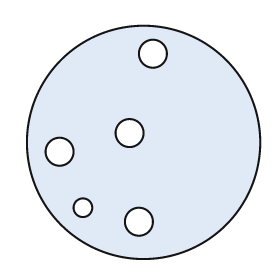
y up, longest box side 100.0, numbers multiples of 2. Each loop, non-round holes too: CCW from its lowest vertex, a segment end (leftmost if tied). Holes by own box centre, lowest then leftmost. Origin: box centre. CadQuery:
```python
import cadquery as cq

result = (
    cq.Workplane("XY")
    .moveTo(0.0, 0.0)
    .circle(50.0)
    .moveTo(-2.0, -34.0)
    .circle(6.0)
    .moveTo(-26.0, -28.0)
    .circle(4.0)
    .moveTo(-36.0, -4.0)
    .circle(6.0)
    .moveTo(-6.0, 4.0)
    .circle(6.0)
    .moveTo(4.0, 38.0)
    .circle(6.0)
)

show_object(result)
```